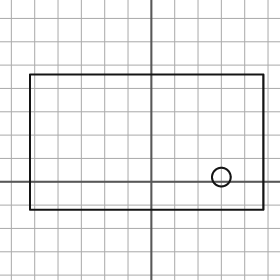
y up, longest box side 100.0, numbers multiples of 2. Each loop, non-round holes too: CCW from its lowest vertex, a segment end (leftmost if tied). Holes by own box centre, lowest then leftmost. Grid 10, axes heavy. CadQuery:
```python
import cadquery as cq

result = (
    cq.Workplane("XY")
    .moveTo(-52.0, -12.0)
    .lineTo(48.0, -12.0)
    .lineTo(48.0, 46.0)
    .lineTo(-52.0, 46.0)
    .close()
    .moveTo(30.0, 2.0)
    .circle(4.0)
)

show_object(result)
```